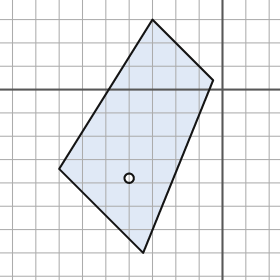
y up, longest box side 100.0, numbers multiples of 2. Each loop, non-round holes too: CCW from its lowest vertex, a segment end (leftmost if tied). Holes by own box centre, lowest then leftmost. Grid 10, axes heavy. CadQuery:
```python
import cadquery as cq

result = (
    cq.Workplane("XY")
    .moveTo(-34.0, -70.0)
    .lineTo(-4.0, 4.0)
    .lineTo(-30.0, 30.0)
    .lineTo(-70.0, -34.0)
    .close()
    .moveTo(-40.0, -38.0)
    .circle(2.0)
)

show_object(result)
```